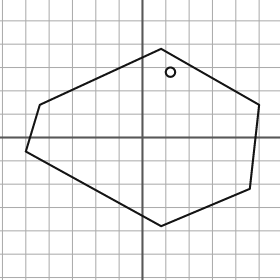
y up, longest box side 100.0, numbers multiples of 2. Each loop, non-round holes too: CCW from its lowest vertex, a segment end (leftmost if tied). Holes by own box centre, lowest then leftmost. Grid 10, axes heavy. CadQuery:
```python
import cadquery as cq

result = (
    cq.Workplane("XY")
    .moveTo(8.0, -38.0)
    .lineTo(46.0, -22.0)
    .lineTo(50.0, 14.0)
    .lineTo(8.0, 38.0)
    .lineTo(-44.0, 14.0)
    .lineTo(-50.0, -6.0)
    .close()
    .moveTo(12.0, 28.0)
    .circle(2.0)
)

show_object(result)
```